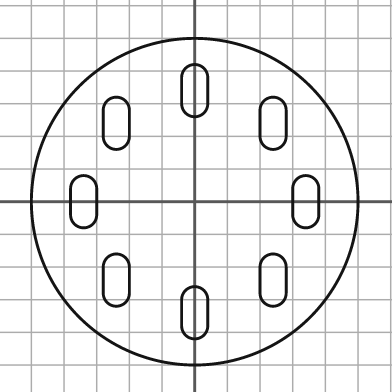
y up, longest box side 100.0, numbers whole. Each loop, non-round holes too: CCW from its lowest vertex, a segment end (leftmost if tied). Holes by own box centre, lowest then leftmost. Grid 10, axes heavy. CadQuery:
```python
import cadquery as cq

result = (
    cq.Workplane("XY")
    .moveTo(0.0, 0.0)
    .circle(50.0)
    .moveTo(-4.0, -38.0)
    .threePointArc((0.0, -42.0), (4.0, -38.0))
    .lineTo(4.0, -30.0)
    .threePointArc((0.0, -26.0), (-4.0, -30.0))
    .close()
    .moveTo(-28.0, -28.0)
    .threePointArc((-24.0, -32.0), (-20.0, -28.0))
    .lineTo(-20.0, -20.0)
    .threePointArc((-24.0, -16.0), (-28.0, -20.0))
    .close()
    .moveTo(20.0, -28.0)
    .threePointArc((24.0, -32.0), (28.0, -28.0))
    .lineTo(28.0, -20.0)
    .threePointArc((24.0, -16.0), (20.0, -20.0))
    .close()
    .moveTo(-38.0, -4.0)
    .threePointArc((-34.0, -8.0), (-30.0, -4.0))
    .lineTo(-30.0, 4.0)
    .threePointArc((-34.0, 8.0), (-38.0, 4.0))
    .close()
    .moveTo(30.0, -4.0)
    .threePointArc((34.0, -8.0), (38.0, -4.0))
    .lineTo(38.0, 4.0)
    .threePointArc((34.0, 8.0), (30.0, 4.0))
    .close()
    .moveTo(-28.0, 20.0)
    .threePointArc((-24.0, 16.0), (-20.0, 20.0))
    .lineTo(-20.0, 28.0)
    .threePointArc((-24.0, 32.0), (-28.0, 28.0))
    .close()
    .moveTo(20.0, 20.0)
    .threePointArc((24.0, 16.0), (28.0, 20.0))
    .lineTo(28.0, 28.0)
    .threePointArc((24.0, 32.0), (20.0, 28.0))
    .close()
    .moveTo(-4.0, 30.0)
    .threePointArc((0.0, 26.0), (4.0, 30.0))
    .lineTo(4.0, 38.0)
    .threePointArc((0.0, 42.0), (-4.0, 38.0))
    .close()
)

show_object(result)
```